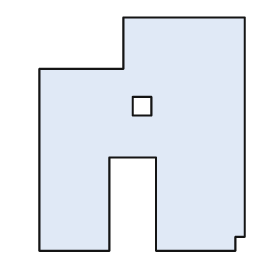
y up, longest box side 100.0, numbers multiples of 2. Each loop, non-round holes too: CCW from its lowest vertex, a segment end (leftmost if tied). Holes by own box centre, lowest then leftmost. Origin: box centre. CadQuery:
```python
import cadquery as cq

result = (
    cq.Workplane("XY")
    .moveTo(-44.0, -50.0)
    .lineTo(-14.0, -50.0)
    .lineTo(-14.0, -10.0)
    .lineTo(6.0, -10.0)
    .lineTo(6.0, -50.0)
    .lineTo(40.0, -50.0)
    .lineTo(40.0, -44.0)
    .lineTo(44.0, -44.0)
    .lineTo(44.0, 50.0)
    .lineTo(-8.0, 50.0)
    .lineTo(-8.0, 28.0)
    .lineTo(-44.0, 28.0)
    .close()
    .moveTo(-4.0, 8.0)
    .lineTo(4.0, 8.0)
    .lineTo(4.0, 16.0)
    .lineTo(-4.0, 16.0)
    .close()
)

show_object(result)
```